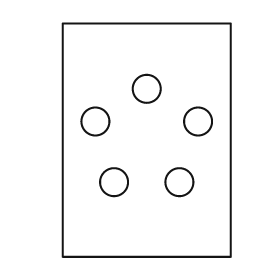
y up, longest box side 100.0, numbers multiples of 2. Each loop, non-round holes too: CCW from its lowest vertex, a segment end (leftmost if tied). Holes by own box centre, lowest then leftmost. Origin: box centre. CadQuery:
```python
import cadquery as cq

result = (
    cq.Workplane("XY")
    .moveTo(-36.0, -50.0)
    .lineTo(36.0, -50.0)
    .lineTo(36.0, 50.0)
    .lineTo(-36.0, 50.0)
    .close()
    .moveTo(-14.0, -18.0)
    .circle(6.0)
    .moveTo(14.0, -18.0)
    .circle(6.0)
    .moveTo(-22.0, 8.0)
    .circle(6.0)
    .moveTo(22.0, 8.0)
    .circle(6.0)
    .moveTo(0.0, 22.0)
    .circle(6.0)
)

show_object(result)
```